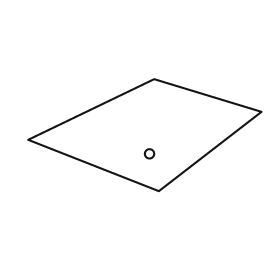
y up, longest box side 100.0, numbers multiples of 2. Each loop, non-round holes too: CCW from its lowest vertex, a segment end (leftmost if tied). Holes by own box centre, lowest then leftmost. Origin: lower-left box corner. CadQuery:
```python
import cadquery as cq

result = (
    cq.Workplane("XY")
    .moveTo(56.0, 0.0)
    .lineTo(100.0, 34.0)
    .lineTo(54.0, 48.0)
    .lineTo(0.0, 22.0)
    .close()
    .moveTo(52.0, 16.0)
    .circle(2.0)
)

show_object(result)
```